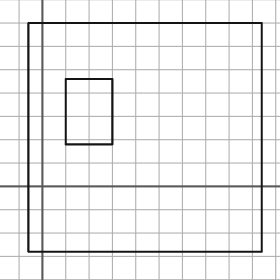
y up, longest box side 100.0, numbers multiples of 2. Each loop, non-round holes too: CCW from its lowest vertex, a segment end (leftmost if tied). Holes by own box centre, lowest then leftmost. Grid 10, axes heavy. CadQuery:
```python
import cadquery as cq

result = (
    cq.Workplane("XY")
    .moveTo(-6.0, -28.0)
    .lineTo(94.0, -28.0)
    .lineTo(94.0, 70.0)
    .lineTo(-6.0, 70.0)
    .close()
    .moveTo(10.0, 18.0)
    .lineTo(30.0, 18.0)
    .lineTo(30.0, 46.0)
    .lineTo(10.0, 46.0)
    .close()
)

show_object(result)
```